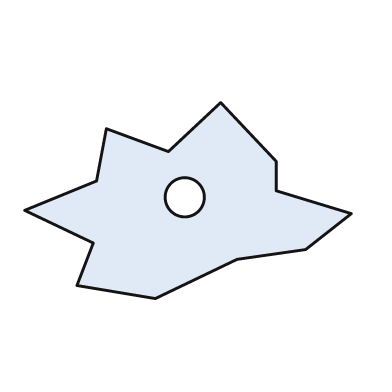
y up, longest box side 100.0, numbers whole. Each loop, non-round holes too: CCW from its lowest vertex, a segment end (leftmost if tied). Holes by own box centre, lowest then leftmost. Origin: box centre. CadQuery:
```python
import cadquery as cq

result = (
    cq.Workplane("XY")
    .moveTo(-10.0, -30.0)
    .lineTo(15.0, -18.0)
    .lineTo(36.0, -15.0)
    .lineTo(50.0, -4.0)
    .lineTo(27.0, 3.0)
    .lineTo(27.0, 12.0)
    .lineTo(10.0, 30.0)
    .lineTo(-6.0, 15.0)
    .lineTo(-25.0, 22.0)
    .lineTo(-28.0, 6.0)
    .lineTo(-50.0, -3.0)
    .lineTo(-29.0, -13.0)
    .lineTo(-34.0, -26.0)
    .close()
    .moveTo(-1.0, 1.0)
    .circle(6.0)
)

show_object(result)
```